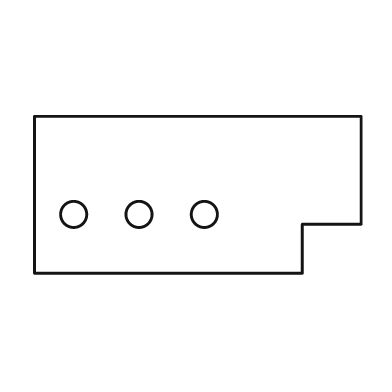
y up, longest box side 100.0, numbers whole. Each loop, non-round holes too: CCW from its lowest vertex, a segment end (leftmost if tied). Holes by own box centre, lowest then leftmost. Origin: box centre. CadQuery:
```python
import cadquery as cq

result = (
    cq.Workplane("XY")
    .moveTo(-50.0, -24.0)
    .lineTo(32.0, -24.0)
    .lineTo(32.0, -9.0)
    .lineTo(50.0, -9.0)
    .lineTo(50.0, 24.0)
    .lineTo(-50.0, 24.0)
    .close()
    .moveTo(-38.0, -6.0)
    .circle(4.0)
    .moveTo(-18.0, -6.0)
    .circle(4.0)
    .moveTo(2.0, -6.0)
    .circle(4.0)
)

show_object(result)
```